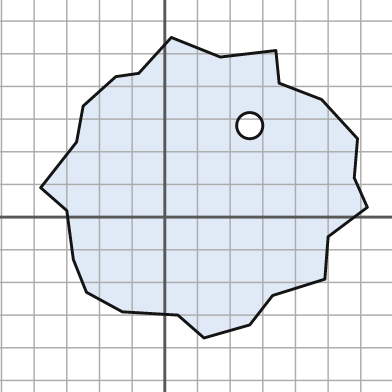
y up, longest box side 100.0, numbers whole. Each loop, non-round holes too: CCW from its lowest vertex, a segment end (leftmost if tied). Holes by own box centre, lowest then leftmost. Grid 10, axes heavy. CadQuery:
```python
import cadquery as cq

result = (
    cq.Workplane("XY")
    .moveTo(12.0, -37.0)
    .lineTo(26.0, -33.0)
    .lineTo(33.0, -24.0)
    .lineTo(49.0, -19.0)
    .lineTo(50.0, -6.0)
    .lineTo(62.0, 3.0)
    .lineTo(58.0, 12.0)
    .lineTo(59.0, 24.0)
    .lineTo(48.0, 36.0)
    .lineTo(35.0, 41.0)
    .lineTo(34.0, 51.0)
    .lineTo(17.0, 49.0)
    .lineTo(2.0, 55.0)
    .lineTo(-8.0, 44.0)
    .lineTo(-15.0, 43.0)
    .lineTo(-25.0, 34.0)
    .lineTo(-27.0, 23.0)
    .lineTo(-38.0, 9.0)
    .lineTo(-30.0, 2.0)
    .lineTo(-28.0, -13.0)
    .lineTo(-24.0, -23.0)
    .lineTo(-13.0, -29.0)
    .lineTo(4.0, -30.0)
    .close()
    .moveTo(26.0, 28.0)
    .circle(4.0)
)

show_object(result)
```